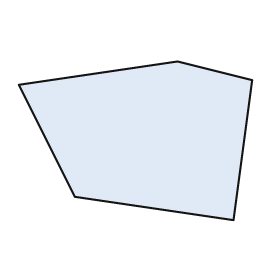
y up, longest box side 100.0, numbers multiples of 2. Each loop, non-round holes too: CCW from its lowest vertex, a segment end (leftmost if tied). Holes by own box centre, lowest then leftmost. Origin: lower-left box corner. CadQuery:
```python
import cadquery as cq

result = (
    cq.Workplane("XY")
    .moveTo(92.0, 0.0)
    .lineTo(100.0, 60.0)
    .lineTo(68.0, 68.0)
    .lineTo(0.0, 58.0)
    .lineTo(24.0, 10.0)
    .close()
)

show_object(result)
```